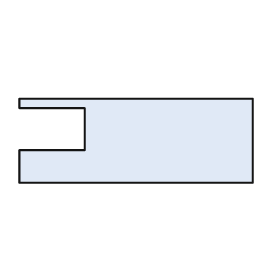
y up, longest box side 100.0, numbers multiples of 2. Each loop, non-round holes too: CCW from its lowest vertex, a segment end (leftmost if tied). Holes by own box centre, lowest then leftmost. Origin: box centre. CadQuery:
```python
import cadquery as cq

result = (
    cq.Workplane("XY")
    .moveTo(-50.0, -18.0)
    .lineTo(50.0, -18.0)
    .lineTo(50.0, 18.0)
    .lineTo(-50.0, 18.0)
    .lineTo(-50.0, 14.0)
    .lineTo(-22.0, 14.0)
    .lineTo(-22.0, -4.0)
    .lineTo(-50.0, -4.0)
    .close()
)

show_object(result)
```